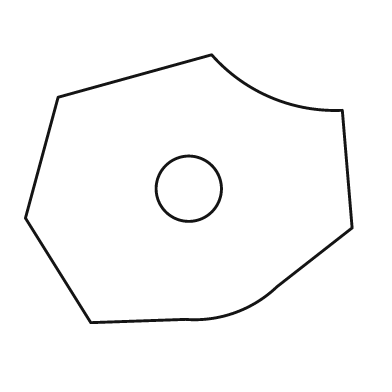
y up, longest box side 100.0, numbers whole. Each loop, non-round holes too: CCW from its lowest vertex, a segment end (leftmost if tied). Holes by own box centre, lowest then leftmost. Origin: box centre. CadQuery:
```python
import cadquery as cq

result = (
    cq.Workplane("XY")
    .moveTo(-30.0, -41.0)
    .lineTo(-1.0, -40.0)
    .threePointArc((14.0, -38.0), (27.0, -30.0))
    .lineTo(50.0, -12.0)
    .lineTo(47.0, 24.0)
    .threePointArc((25.0, 28.0), (7.0, 41.0))
    .lineTo(-40.0, 28.0)
    .lineTo(-50.0, -9.0)
    .close()
    .moveTo(0.0, 0.0)
    .circle(10.0)
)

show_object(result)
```